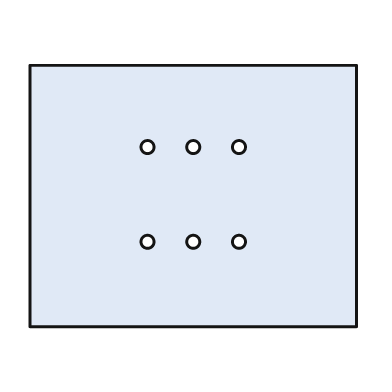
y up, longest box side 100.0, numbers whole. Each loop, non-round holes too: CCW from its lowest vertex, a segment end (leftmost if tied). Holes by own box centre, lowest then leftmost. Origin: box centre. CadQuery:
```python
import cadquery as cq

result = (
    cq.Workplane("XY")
    .moveTo(-50.0, -40.0)
    .lineTo(50.0, -40.0)
    .lineTo(50.0, 40.0)
    .lineTo(-50.0, 40.0)
    .close()
    .moveTo(-14.0, -14.0)
    .circle(2.0)
    .moveTo(0.0, -14.0)
    .circle(2.0)
    .moveTo(14.0, -14.0)
    .circle(2.0)
    .moveTo(-14.0, 15.0)
    .circle(2.0)
    .moveTo(0.0, 15.0)
    .circle(2.0)
    .moveTo(14.0, 15.0)
    .circle(2.0)
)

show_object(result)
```